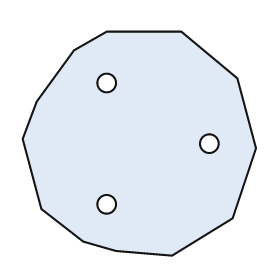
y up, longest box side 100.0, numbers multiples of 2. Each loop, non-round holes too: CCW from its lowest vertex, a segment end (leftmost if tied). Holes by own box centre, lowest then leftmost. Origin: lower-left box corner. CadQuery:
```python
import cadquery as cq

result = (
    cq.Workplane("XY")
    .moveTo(64.0, 0.0)
    .lineTo(90.0, 16.0)
    .lineTo(100.0, 46.0)
    .lineTo(92.0, 76.0)
    .lineTo(68.0, 96.0)
    .lineTo(36.0, 96.0)
    .lineTo(22.0, 88.0)
    .lineTo(6.0, 66.0)
    .lineTo(0.0, 50.0)
    .lineTo(8.0, 20.0)
    .lineTo(26.0, 6.0)
    .lineTo(40.0, 2.0)
    .close()
    .moveTo(36.0, 22.0)
    .circle(4.0)
    .moveTo(80.0, 48.0)
    .circle(4.0)
    .moveTo(36.0, 74.0)
    .circle(4.0)
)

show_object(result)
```